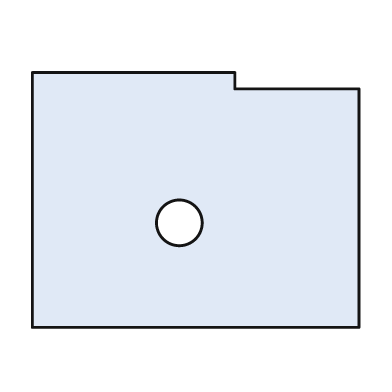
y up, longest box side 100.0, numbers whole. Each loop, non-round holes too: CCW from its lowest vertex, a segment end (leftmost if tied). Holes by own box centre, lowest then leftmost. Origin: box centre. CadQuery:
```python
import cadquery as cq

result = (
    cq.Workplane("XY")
    .moveTo(-50.0, -39.0)
    .lineTo(50.0, -39.0)
    .lineTo(50.0, 34.0)
    .lineTo(12.0, 34.0)
    .lineTo(12.0, 39.0)
    .lineTo(-50.0, 39.0)
    .close()
    .moveTo(-5.0, -7.0)
    .circle(7.0)
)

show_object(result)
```